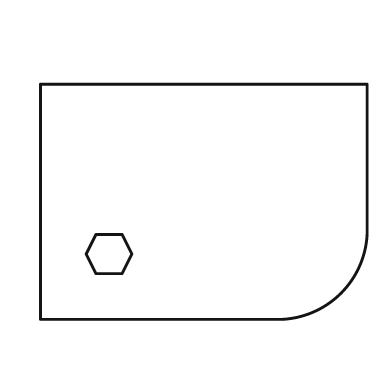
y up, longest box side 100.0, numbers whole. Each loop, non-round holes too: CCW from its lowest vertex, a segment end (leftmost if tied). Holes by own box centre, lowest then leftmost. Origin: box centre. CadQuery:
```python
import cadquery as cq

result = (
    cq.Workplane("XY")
    .moveTo(-50.0, -36.0)
    .lineTo(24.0, -36.0)
    .threePointArc((42.0, -28.0), (50.0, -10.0))
    .lineTo(50.0, 36.0)
    .lineTo(-50.0, 36.0)
    .close()
    .moveTo(-33.0, -22.0)
    .lineTo(-25.0, -22.0)
    .lineTo(-22.0, -16.0)
    .lineTo(-25.0, -10.0)
    .lineTo(-33.0, -10.0)
    .lineTo(-36.0, -16.0)
    .close()
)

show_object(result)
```